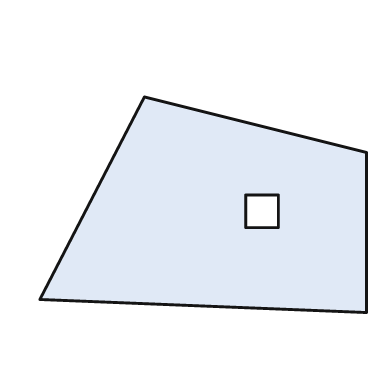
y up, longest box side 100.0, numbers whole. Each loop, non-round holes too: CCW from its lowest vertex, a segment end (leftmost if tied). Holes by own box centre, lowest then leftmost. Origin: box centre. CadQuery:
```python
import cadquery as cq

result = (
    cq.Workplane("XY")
    .moveTo(50.0, -33.0)
    .lineTo(50.0, 16.0)
    .lineTo(-18.0, 33.0)
    .lineTo(-50.0, -29.0)
    .close()
    .moveTo(13.0, -7.0)
    .lineTo(23.0, -7.0)
    .lineTo(23.0, 3.0)
    .lineTo(13.0, 3.0)
    .close()
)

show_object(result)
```